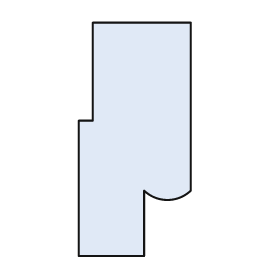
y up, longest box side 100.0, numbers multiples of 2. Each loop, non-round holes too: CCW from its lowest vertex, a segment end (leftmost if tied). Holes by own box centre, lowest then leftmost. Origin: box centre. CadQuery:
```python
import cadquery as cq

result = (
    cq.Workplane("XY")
    .moveTo(-24.0, -50.0)
    .lineTo(4.0, -50.0)
    .lineTo(4.0, -22.0)
    .threePointArc((14.0, -26.0), (24.0, -22.0))
    .lineTo(24.0, 50.0)
    .lineTo(-18.0, 50.0)
    .lineTo(-18.0, 8.0)
    .lineTo(-24.0, 8.0)
    .close()
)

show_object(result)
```